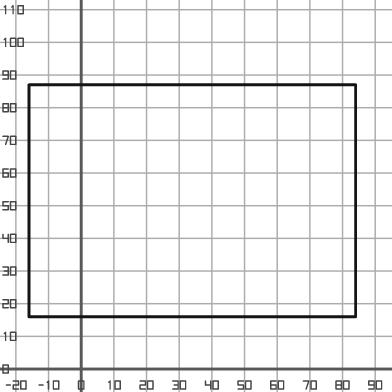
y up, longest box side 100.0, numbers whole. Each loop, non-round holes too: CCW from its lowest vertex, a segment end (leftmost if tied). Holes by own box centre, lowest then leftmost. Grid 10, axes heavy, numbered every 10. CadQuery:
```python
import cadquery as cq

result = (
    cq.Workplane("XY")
    .moveTo(-16.0, 16.0)
    .lineTo(84.0, 16.0)
    .lineTo(84.0, 87.0)
    .lineTo(-16.0, 87.0)
    .close()
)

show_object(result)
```